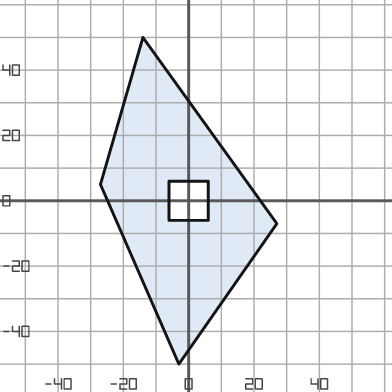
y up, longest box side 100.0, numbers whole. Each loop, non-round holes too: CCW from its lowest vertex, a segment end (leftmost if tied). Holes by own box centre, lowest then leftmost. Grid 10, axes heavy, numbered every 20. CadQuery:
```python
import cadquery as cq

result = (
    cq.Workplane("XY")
    .moveTo(-3.0, -50.0)
    .lineTo(27.0, -7.0)
    .lineTo(-14.0, 50.0)
    .lineTo(-27.0, 5.0)
    .close()
    .moveTo(-6.0, -6.0)
    .lineTo(6.0, -6.0)
    .lineTo(6.0, 6.0)
    .lineTo(-6.0, 6.0)
    .close()
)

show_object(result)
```